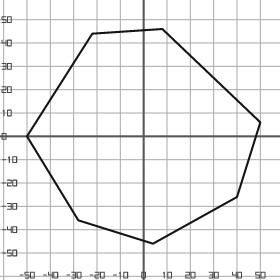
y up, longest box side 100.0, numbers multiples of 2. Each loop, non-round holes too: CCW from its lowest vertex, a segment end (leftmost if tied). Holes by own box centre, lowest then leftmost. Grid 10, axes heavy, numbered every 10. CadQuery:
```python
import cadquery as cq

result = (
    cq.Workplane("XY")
    .moveTo(4.0, -46.0)
    .lineTo(40.0, -26.0)
    .lineTo(50.0, 6.0)
    .lineTo(8.0, 46.0)
    .lineTo(-22.0, 44.0)
    .lineTo(-50.0, 0.0)
    .lineTo(-28.0, -36.0)
    .close()
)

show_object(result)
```